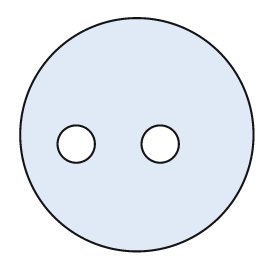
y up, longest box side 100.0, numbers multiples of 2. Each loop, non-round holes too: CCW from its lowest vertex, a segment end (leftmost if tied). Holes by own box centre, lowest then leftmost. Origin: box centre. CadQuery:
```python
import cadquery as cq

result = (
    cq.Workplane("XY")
    .moveTo(0.0, 0.0)
    .circle(50.0)
    .moveTo(-26.0, -4.0)
    .circle(8.0)
    .moveTo(10.0, -4.0)
    .circle(8.0)
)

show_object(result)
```